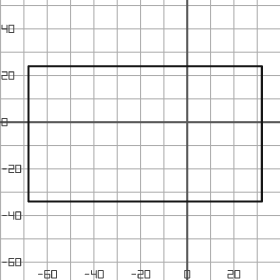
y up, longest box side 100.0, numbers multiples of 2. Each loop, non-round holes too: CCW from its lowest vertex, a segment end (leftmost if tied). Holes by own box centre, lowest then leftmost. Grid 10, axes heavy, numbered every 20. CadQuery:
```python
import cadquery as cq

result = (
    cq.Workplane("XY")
    .moveTo(-68.0, -34.0)
    .lineTo(32.0, -34.0)
    .lineTo(32.0, 24.0)
    .lineTo(-68.0, 24.0)
    .close()
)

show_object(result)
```